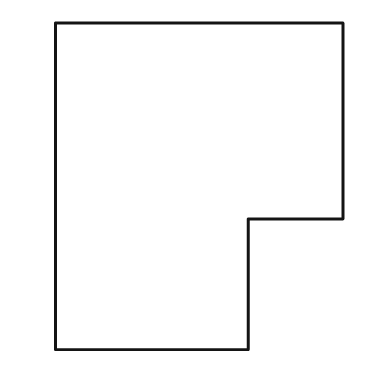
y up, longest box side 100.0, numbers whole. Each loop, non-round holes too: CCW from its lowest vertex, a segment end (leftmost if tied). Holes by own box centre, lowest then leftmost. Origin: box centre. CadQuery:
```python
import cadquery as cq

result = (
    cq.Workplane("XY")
    .moveTo(-44.0, -50.0)
    .lineTo(15.0, -50.0)
    .lineTo(15.0, -10.0)
    .lineTo(44.0, -10.0)
    .lineTo(44.0, 50.0)
    .lineTo(-44.0, 50.0)
    .close()
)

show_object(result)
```